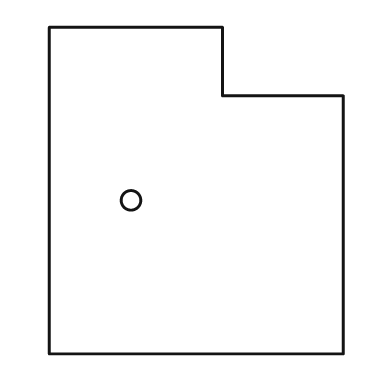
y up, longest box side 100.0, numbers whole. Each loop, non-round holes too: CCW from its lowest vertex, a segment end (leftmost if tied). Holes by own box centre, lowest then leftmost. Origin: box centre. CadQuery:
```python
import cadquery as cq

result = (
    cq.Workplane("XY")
    .moveTo(-45.0, -50.0)
    .lineTo(45.0, -50.0)
    .lineTo(45.0, 29.0)
    .lineTo(8.0, 29.0)
    .lineTo(8.0, 50.0)
    .lineTo(-45.0, 50.0)
    .close()
    .moveTo(-20.0, -3.0)
    .circle(3.0)
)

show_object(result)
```